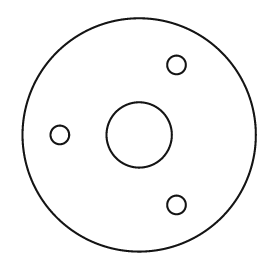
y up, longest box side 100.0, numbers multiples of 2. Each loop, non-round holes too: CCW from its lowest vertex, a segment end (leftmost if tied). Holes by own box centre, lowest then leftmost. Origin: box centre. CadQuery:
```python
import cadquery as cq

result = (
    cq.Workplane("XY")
    .moveTo(0.0, 0.0)
    .circle(50.0)
    .moveTo(16.0, -30.0)
    .circle(4.0)
    .moveTo(-34.0, 0.0)
    .circle(4.0)
    .moveTo(0.0, 0.0)
    .circle(14.0)
    .moveTo(16.0, 30.0)
    .circle(4.0)
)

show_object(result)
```